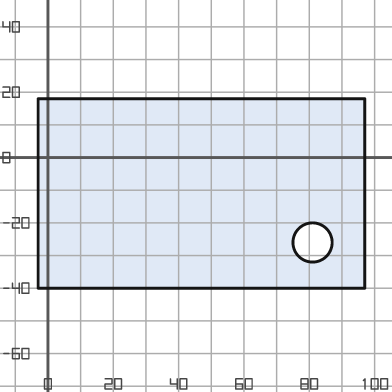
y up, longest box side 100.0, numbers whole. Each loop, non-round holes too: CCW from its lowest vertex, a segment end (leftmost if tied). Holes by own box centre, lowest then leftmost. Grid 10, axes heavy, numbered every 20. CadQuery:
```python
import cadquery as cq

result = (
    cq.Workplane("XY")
    .moveTo(-3.0, -40.0)
    .lineTo(97.0, -40.0)
    .lineTo(97.0, 18.0)
    .lineTo(-3.0, 18.0)
    .close()
    .moveTo(81.0, -26.0)
    .circle(6.0)
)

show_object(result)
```